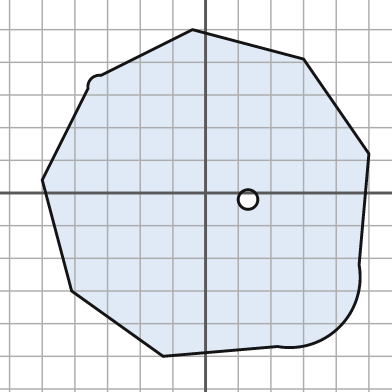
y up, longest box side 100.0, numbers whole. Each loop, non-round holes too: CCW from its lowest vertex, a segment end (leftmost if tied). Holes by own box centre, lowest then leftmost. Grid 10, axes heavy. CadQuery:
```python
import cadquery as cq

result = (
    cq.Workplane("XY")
    .moveTo(-13.0, -50.0)
    .lineTo(22.0, -47.0)
    .threePointArc((41.0, -41.0), (47.0, -22.0))
    .lineTo(50.0, 12.0)
    .lineTo(30.0, 41.0)
    .lineTo(-4.0, 50.0)
    .lineTo(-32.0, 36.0)
    .threePointArc((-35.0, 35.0), (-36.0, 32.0))
    .lineTo(-50.0, 4.0)
    .lineTo(-41.0, -30.0)
    .close()
    .moveTo(13.0, -2.0)
    .circle(3.0)
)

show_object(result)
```